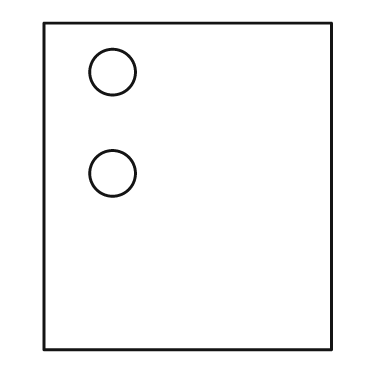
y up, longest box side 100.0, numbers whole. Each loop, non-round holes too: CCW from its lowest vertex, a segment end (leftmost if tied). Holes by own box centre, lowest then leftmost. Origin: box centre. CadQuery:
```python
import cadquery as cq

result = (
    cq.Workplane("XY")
    .moveTo(-44.0, -50.0)
    .lineTo(44.0, -50.0)
    .lineTo(44.0, 50.0)
    .lineTo(-44.0, 50.0)
    .close()
    .moveTo(-23.0, 4.0)
    .circle(7.0)
    .moveTo(-23.0, 35.0)
    .circle(7.0)
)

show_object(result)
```